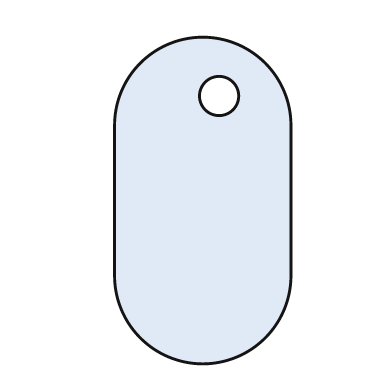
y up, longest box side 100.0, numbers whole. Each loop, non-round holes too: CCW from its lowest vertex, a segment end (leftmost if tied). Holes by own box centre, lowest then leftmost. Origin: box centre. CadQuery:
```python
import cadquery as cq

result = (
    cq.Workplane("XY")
    .moveTo(-27.0, -23.0)
    .threePointArc((0.0, -50.0), (27.0, -23.0))
    .lineTo(27.0, 23.0)
    .threePointArc((0.0, 50.0), (-27.0, 23.0))
    .close()
    .moveTo(5.0, 32.0)
    .circle(6.0)
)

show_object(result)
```